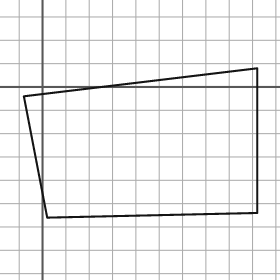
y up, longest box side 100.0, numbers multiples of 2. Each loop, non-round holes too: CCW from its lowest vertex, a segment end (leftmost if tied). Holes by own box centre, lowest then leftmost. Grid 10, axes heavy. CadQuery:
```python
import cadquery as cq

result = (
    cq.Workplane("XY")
    .moveTo(2.0, -56.0)
    .lineTo(92.0, -54.0)
    .lineTo(92.0, 8.0)
    .lineTo(-8.0, -4.0)
    .close()
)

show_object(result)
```